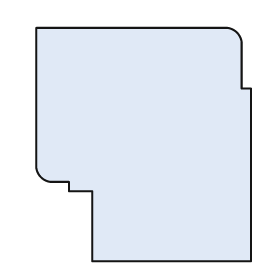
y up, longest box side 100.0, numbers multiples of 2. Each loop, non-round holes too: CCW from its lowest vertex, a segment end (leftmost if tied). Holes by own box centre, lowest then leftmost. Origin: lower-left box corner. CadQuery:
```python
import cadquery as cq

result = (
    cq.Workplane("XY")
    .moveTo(24.0, 0.0)
    .lineTo(92.0, 0.0)
    .lineTo(92.0, 74.0)
    .lineTo(88.0, 74.0)
    .lineTo(88.0, 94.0)
    .threePointArc((86.0, 98.0), (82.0, 100.0))
    .lineTo(0.0, 100.0)
    .lineTo(0.0, 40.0)
    .threePointArc((2.0, 36.0), (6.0, 34.0))
    .lineTo(14.0, 34.0)
    .lineTo(14.0, 30.0)
    .lineTo(24.0, 30.0)
    .close()
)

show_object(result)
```